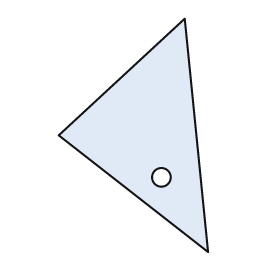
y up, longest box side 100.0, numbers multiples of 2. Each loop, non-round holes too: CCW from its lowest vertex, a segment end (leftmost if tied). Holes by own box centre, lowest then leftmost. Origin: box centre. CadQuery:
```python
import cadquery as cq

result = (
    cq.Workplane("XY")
    .moveTo(32.0, -50.0)
    .lineTo(22.0, 50.0)
    .lineTo(-32.0, 0.0)
    .close()
    .moveTo(12.0, -18.0)
    .circle(4.0)
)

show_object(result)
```